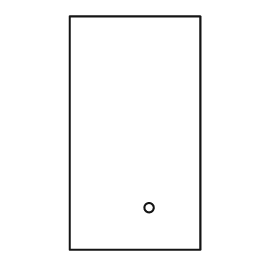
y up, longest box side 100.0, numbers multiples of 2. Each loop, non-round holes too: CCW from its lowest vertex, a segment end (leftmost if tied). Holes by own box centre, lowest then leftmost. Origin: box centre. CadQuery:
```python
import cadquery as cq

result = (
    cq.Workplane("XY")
    .moveTo(-28.0, -50.0)
    .lineTo(28.0, -50.0)
    .lineTo(28.0, 50.0)
    .lineTo(-28.0, 50.0)
    .close()
    .moveTo(6.0, -32.0)
    .circle(2.0)
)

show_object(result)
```